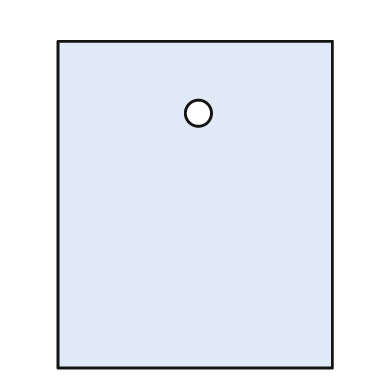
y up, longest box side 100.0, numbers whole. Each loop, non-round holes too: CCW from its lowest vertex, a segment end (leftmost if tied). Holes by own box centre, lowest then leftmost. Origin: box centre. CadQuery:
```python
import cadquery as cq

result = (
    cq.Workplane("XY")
    .moveTo(-42.0, -50.0)
    .lineTo(42.0, -50.0)
    .lineTo(42.0, 50.0)
    .lineTo(-42.0, 50.0)
    .close()
    .moveTo(1.0, 28.0)
    .circle(4.0)
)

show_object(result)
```